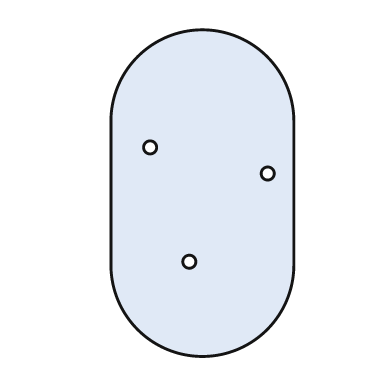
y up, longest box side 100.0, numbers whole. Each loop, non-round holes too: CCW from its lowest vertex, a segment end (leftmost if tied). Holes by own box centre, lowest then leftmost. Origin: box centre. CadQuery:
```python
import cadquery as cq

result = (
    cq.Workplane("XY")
    .moveTo(-28.0, -22.0)
    .threePointArc((0.0, -50.0), (28.0, -22.0))
    .lineTo(28.0, 22.0)
    .threePointArc((0.0, 50.0), (-28.0, 22.0))
    .close()
    .moveTo(-4.0, -21.0)
    .circle(2.0)
    .moveTo(20.0, 6.0)
    .circle(2.0)
    .moveTo(-16.0, 14.0)
    .circle(2.0)
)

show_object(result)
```